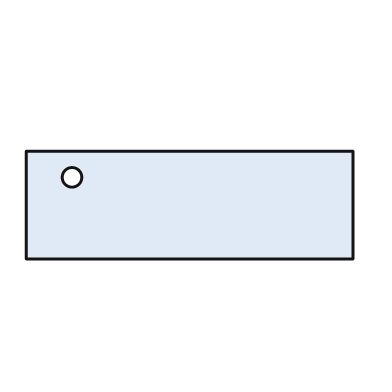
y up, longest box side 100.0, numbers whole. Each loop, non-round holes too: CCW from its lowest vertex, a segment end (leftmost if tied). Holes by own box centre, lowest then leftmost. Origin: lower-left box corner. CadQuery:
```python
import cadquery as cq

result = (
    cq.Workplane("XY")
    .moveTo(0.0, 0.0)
    .lineTo(100.0, 0.0)
    .lineTo(100.0, 33.0)
    .lineTo(0.0, 33.0)
    .close()
    .moveTo(14.0, 25.0)
    .circle(3.0)
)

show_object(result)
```